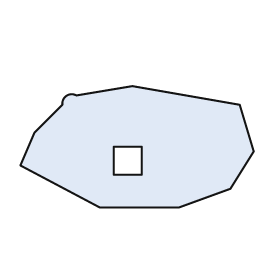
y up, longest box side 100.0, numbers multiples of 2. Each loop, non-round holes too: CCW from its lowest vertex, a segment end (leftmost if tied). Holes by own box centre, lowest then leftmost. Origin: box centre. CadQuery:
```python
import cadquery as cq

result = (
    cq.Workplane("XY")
    .moveTo(-16.0, -26.0)
    .lineTo(18.0, -26.0)
    .lineTo(40.0, -18.0)
    .lineTo(50.0, -2.0)
    .lineTo(44.0, 18.0)
    .lineTo(-2.0, 26.0)
    .lineTo(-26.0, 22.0)
    .threePointArc((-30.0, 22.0), (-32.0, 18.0))
    .lineTo(-44.0, 6.0)
    .lineTo(-50.0, -8.0)
    .close()
    .moveTo(-10.0, -12.0)
    .lineTo(2.0, -12.0)
    .lineTo(2.0, 0.0)
    .lineTo(-10.0, 0.0)
    .close()
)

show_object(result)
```